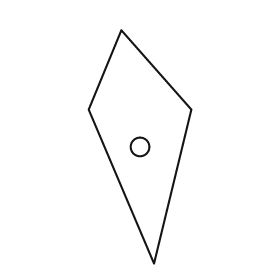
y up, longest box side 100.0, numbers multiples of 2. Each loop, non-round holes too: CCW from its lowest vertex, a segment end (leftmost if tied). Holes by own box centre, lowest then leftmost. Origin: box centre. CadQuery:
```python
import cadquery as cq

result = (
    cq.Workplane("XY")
    .moveTo(6.0, -50.0)
    .lineTo(22.0, 16.0)
    .lineTo(-8.0, 50.0)
    .lineTo(-22.0, 16.0)
    .close()
    .moveTo(0.0, 0.0)
    .circle(4.0)
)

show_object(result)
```